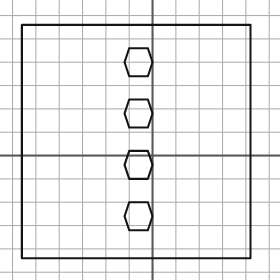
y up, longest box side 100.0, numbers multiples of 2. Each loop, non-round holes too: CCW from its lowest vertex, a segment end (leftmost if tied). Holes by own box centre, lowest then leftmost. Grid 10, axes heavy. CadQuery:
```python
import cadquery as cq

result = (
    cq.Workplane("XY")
    .moveTo(-56.0, -44.0)
    .lineTo(42.0, -44.0)
    .lineTo(42.0, 56.0)
    .lineTo(-56.0, 56.0)
    .close()
    .moveTo(-10.0, -32.0)
    .lineTo(-2.0, -32.0)
    .lineTo(0.0, -26.0)
    .lineTo(-2.0, -20.0)
    .lineTo(-10.0, -20.0)
    .lineTo(-12.0, -26.0)
    .close()
    .moveTo(-10.0, -10.0)
    .lineTo(-2.0, -10.0)
    .lineTo(0.0, -4.0)
    .lineTo(-2.0, 2.0)
    .lineTo(-10.0, 2.0)
    .lineTo(-12.0, -4.0)
    .close()
    .moveTo(-10.0, 12.0)
    .lineTo(-2.0, 12.0)
    .lineTo(0.0, 18.0)
    .lineTo(-2.0, 24.0)
    .lineTo(-10.0, 24.0)
    .lineTo(-12.0, 18.0)
    .close()
    .moveTo(-10.0, 34.0)
    .lineTo(-2.0, 34.0)
    .lineTo(0.0, 40.0)
    .lineTo(-2.0, 46.0)
    .lineTo(-10.0, 46.0)
    .lineTo(-12.0, 40.0)
    .close()
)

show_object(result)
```